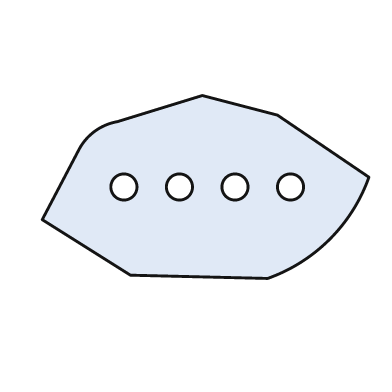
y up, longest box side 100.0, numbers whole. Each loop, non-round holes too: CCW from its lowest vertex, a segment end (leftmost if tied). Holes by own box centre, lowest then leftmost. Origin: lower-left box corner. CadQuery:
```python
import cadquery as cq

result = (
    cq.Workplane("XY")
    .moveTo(69.0, 0.0)
    .threePointArc((88.0, 12.0), (100.0, 31.0))
    .lineTo(72.0, 50.0)
    .lineTo(49.0, 56.0)
    .lineTo(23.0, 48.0)
    .threePointArc((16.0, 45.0), (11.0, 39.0))
    .lineTo(0.0, 18.0)
    .lineTo(27.0, 1.0)
    .close()
    .moveTo(25.0, 28.0)
    .circle(4.0)
    .moveTo(42.0, 28.0)
    .circle(4.0)
    .moveTo(59.0, 28.0)
    .circle(4.0)
    .moveTo(76.0, 28.0)
    .circle(4.0)
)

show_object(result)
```